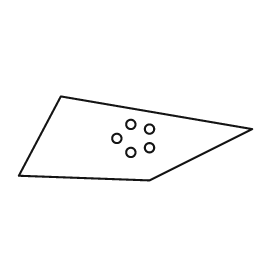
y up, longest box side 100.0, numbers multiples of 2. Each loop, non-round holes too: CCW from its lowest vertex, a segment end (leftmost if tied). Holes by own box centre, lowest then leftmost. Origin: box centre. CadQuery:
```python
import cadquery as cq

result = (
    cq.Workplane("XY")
    .moveTo(6.0, -18.0)
    .lineTo(50.0, 4.0)
    .lineTo(-32.0, 18.0)
    .lineTo(-50.0, -16.0)
    .close()
    .moveTo(-2.0, -6.0)
    .circle(2.0)
    .moveTo(6.0, -4.0)
    .circle(2.0)
    .moveTo(-8.0, 0.0)
    .circle(2.0)
    .moveTo(6.0, 4.0)
    .circle(2.0)
    .moveTo(-2.0, 6.0)
    .circle(2.0)
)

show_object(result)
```